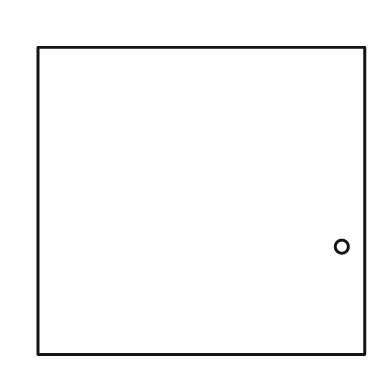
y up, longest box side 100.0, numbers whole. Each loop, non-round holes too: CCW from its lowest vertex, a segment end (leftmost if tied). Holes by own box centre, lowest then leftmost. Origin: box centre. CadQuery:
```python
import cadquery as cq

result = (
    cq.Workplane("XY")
    .moveTo(-50.0, -47.0)
    .lineTo(50.0, -47.0)
    .lineTo(50.0, 47.0)
    .lineTo(-50.0, 47.0)
    .close()
    .moveTo(43.0, -14.0)
    .circle(2.0)
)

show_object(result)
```